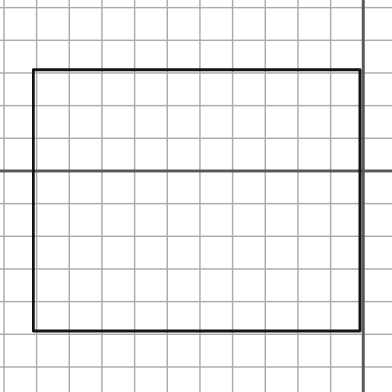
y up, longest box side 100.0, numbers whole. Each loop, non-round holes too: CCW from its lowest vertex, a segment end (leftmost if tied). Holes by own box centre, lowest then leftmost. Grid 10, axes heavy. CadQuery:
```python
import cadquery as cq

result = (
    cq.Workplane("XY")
    .moveTo(-101.0, -49.0)
    .lineTo(-1.0, -49.0)
    .lineTo(-1.0, 31.0)
    .lineTo(-101.0, 31.0)
    .close()
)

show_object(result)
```